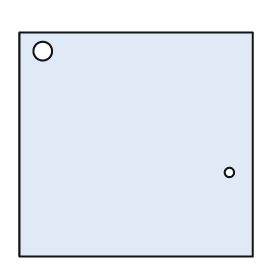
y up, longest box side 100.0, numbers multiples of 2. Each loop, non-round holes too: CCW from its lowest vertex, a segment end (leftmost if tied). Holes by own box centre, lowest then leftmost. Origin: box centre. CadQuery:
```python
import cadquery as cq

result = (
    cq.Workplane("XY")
    .moveTo(-50.0, -48.0)
    .lineTo(50.0, -48.0)
    .lineTo(50.0, 48.0)
    .lineTo(-50.0, 48.0)
    .close()
    .moveTo(40.0, -12.0)
    .circle(2.0)
    .moveTo(-40.0, 40.0)
    .circle(4.0)
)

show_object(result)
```